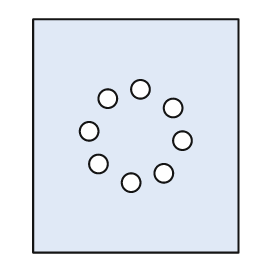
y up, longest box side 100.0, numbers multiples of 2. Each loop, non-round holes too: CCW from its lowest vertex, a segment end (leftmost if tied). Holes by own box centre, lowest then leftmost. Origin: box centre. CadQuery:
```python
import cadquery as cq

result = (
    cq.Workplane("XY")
    .moveTo(-44.0, -50.0)
    .lineTo(44.0, -50.0)
    .lineTo(44.0, 50.0)
    .lineTo(-44.0, 50.0)
    .close()
    .moveTo(-2.0, -20.0)
    .circle(4.0)
    .moveTo(12.0, -16.0)
    .circle(4.0)
    .moveTo(-16.0, -12.0)
    .circle(4.0)
    .moveTo(20.0, -2.0)
    .circle(4.0)
    .moveTo(-20.0, 2.0)
    .circle(4.0)
    .moveTo(16.0, 12.0)
    .circle(4.0)
    .moveTo(-12.0, 16.0)
    .circle(4.0)
    .moveTo(2.0, 20.0)
    .circle(4.0)
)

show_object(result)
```